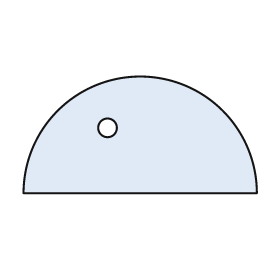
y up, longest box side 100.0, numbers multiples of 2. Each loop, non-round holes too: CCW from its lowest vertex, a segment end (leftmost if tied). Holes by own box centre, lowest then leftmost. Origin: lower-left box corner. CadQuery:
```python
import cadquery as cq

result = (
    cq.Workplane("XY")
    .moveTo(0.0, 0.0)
    .lineTo(100.0, 0.0)
    .threePointArc((50.0, 50.0), (0.0, 0.0))
    .close()
    .moveTo(36.0, 28.0)
    .circle(4.0)
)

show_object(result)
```